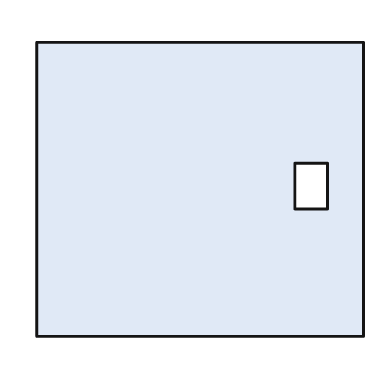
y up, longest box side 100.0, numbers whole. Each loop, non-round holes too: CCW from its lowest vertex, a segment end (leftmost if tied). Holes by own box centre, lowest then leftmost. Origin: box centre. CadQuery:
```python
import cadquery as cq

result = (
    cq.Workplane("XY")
    .moveTo(-50.0, -45.0)
    .lineTo(50.0, -45.0)
    .lineTo(50.0, 45.0)
    .lineTo(-50.0, 45.0)
    .close()
    .moveTo(29.0, -6.0)
    .lineTo(39.0, -6.0)
    .lineTo(39.0, 8.0)
    .lineTo(29.0, 8.0)
    .close()
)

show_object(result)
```